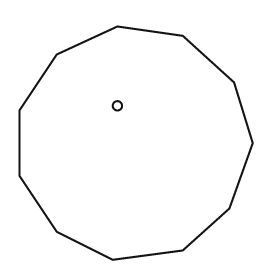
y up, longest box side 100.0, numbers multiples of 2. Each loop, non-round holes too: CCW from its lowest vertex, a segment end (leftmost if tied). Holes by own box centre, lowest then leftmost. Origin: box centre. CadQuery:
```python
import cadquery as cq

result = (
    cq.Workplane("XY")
    .moveTo(-10.0, -50.0)
    .lineTo(20.0, -46.0)
    .lineTo(40.0, -28.0)
    .lineTo(50.0, 0.0)
    .lineTo(42.0, 26.0)
    .lineTo(20.0, 46.0)
    .lineTo(-8.0, 50.0)
    .lineTo(-34.0, 38.0)
    .lineTo(-50.0, 14.0)
    .lineTo(-50.0, -14.0)
    .lineTo(-34.0, -38.0)
    .close()
    .moveTo(-8.0, 16.0)
    .circle(2.0)
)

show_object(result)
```